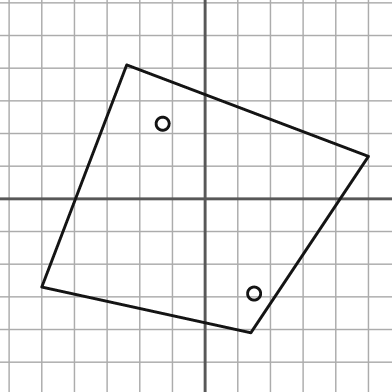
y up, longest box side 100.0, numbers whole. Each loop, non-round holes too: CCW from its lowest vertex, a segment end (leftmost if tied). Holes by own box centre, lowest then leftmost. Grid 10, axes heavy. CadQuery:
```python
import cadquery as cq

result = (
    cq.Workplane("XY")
    .moveTo(14.0, -41.0)
    .lineTo(50.0, 13.0)
    .lineTo(-24.0, 41.0)
    .lineTo(-50.0, -27.0)
    .close()
    .moveTo(15.0, -29.0)
    .circle(2.0)
    .moveTo(-13.0, 23.0)
    .circle(2.0)
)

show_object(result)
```